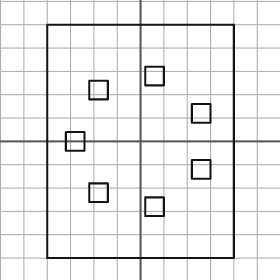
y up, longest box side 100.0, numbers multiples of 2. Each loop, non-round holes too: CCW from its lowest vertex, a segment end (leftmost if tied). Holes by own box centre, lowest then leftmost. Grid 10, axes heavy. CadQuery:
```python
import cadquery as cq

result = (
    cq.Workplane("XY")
    .moveTo(-40.0, -50.0)
    .lineTo(40.0, -50.0)
    .lineTo(40.0, 50.0)
    .lineTo(-40.0, 50.0)
    .close()
    .moveTo(2.0, -32.0)
    .lineTo(10.0, -32.0)
    .lineTo(10.0, -24.0)
    .lineTo(2.0, -24.0)
    .close()
    .moveTo(-22.0, -26.0)
    .lineTo(-14.0, -26.0)
    .lineTo(-14.0, -18.0)
    .lineTo(-22.0, -18.0)
    .close()
    .moveTo(22.0, -16.0)
    .lineTo(30.0, -16.0)
    .lineTo(30.0, -8.0)
    .lineTo(22.0, -8.0)
    .close()
    .moveTo(-32.0, -4.0)
    .lineTo(-24.0, -4.0)
    .lineTo(-24.0, 4.0)
    .lineTo(-32.0, 4.0)
    .close()
    .moveTo(22.0, 8.0)
    .lineTo(30.0, 8.0)
    .lineTo(30.0, 16.0)
    .lineTo(22.0, 16.0)
    .close()
    .moveTo(-22.0, 18.0)
    .lineTo(-14.0, 18.0)
    .lineTo(-14.0, 26.0)
    .lineTo(-22.0, 26.0)
    .close()
    .moveTo(2.0, 24.0)
    .lineTo(10.0, 24.0)
    .lineTo(10.0, 32.0)
    .lineTo(2.0, 32.0)
    .close()
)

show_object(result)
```